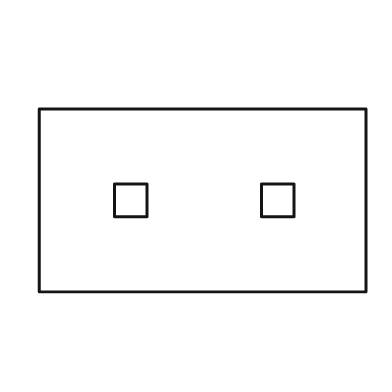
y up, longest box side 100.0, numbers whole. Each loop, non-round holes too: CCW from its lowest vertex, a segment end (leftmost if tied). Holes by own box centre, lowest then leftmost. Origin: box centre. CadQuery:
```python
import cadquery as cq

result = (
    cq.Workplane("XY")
    .moveTo(-50.0, -28.0)
    .lineTo(50.0, -28.0)
    .lineTo(50.0, 28.0)
    .lineTo(-50.0, 28.0)
    .close()
    .moveTo(-27.0, -5.0)
    .lineTo(-17.0, -5.0)
    .lineTo(-17.0, 5.0)
    .lineTo(-27.0, 5.0)
    .close()
    .moveTo(18.0, -5.0)
    .lineTo(28.0, -5.0)
    .lineTo(28.0, 5.0)
    .lineTo(18.0, 5.0)
    .close()
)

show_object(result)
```